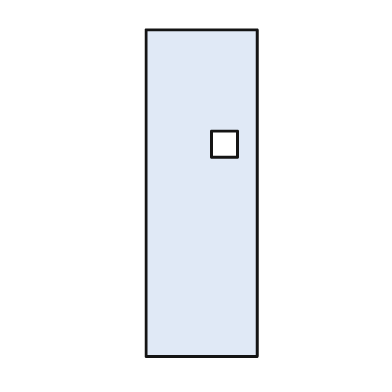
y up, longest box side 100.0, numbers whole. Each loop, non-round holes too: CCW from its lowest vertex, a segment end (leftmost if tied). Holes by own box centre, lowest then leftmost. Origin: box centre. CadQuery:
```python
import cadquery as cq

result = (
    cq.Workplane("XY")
    .moveTo(-17.0, -50.0)
    .lineTo(17.0, -50.0)
    .lineTo(17.0, 50.0)
    .lineTo(-17.0, 50.0)
    .close()
    .moveTo(3.0, 11.0)
    .lineTo(11.0, 11.0)
    .lineTo(11.0, 19.0)
    .lineTo(3.0, 19.0)
    .close()
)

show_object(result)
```